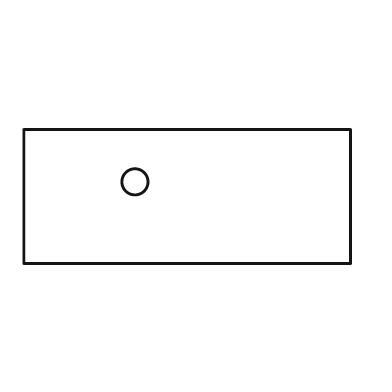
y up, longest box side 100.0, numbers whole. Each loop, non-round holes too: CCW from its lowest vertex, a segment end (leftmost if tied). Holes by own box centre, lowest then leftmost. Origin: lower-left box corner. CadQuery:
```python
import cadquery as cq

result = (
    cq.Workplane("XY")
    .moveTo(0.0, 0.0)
    .lineTo(100.0, 0.0)
    .lineTo(100.0, 41.0)
    .lineTo(0.0, 41.0)
    .close()
    .moveTo(34.0, 25.0)
    .circle(4.0)
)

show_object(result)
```